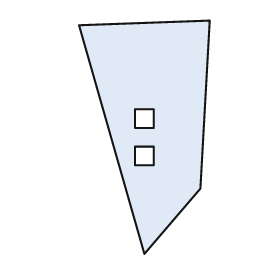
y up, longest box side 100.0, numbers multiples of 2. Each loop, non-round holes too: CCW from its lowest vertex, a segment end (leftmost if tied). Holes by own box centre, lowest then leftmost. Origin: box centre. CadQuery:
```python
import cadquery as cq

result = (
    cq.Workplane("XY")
    .moveTo(0.0, -50.0)
    .lineTo(24.0, -22.0)
    .lineTo(28.0, 50.0)
    .lineTo(-28.0, 48.0)
    .close()
    .moveTo(-4.0, -12.0)
    .lineTo(4.0, -12.0)
    .lineTo(4.0, -4.0)
    .lineTo(-4.0, -4.0)
    .close()
    .moveTo(-4.0, 4.0)
    .lineTo(4.0, 4.0)
    .lineTo(4.0, 12.0)
    .lineTo(-4.0, 12.0)
    .close()
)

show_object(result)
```